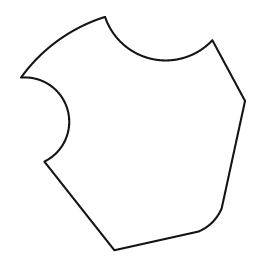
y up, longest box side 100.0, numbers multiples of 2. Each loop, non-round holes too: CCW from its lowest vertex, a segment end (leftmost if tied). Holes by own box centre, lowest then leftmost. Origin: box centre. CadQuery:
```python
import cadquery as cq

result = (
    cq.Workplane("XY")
    .moveTo(-8.0, -50.0)
    .lineTo(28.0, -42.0)
    .threePointArc((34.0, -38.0), (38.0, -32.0))
    .lineTo(48.0, 14.0)
    .lineTo(34.0, 40.0)
    .threePointArc((8.0, 32.0), (-12.0, 50.0))
    .threePointArc((-32.0, 40.0), (-48.0, 24.0))
    .threePointArc((-28.0, 10.0), (-38.0, -12.0))
    .close()
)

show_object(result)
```